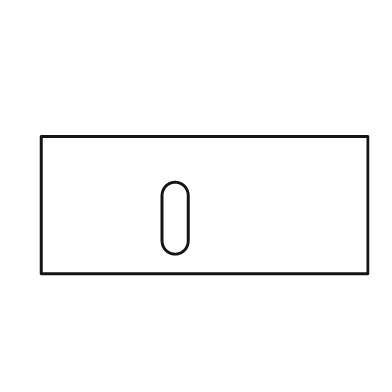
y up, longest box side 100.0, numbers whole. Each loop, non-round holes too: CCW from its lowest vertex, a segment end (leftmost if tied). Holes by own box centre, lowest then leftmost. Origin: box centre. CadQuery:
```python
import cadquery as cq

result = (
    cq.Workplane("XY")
    .moveTo(-50.0, -21.0)
    .lineTo(50.0, -21.0)
    .lineTo(50.0, 21.0)
    .lineTo(-50.0, 21.0)
    .close()
    .moveTo(-13.0, -11.0)
    .threePointArc((-9.0, -15.0), (-5.0, -11.0))
    .lineTo(-5.0, 3.0)
    .threePointArc((-9.0, 7.0), (-13.0, 3.0))
    .close()
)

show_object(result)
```